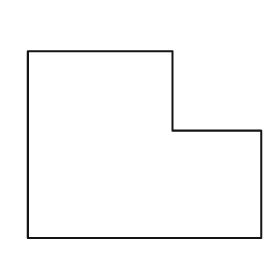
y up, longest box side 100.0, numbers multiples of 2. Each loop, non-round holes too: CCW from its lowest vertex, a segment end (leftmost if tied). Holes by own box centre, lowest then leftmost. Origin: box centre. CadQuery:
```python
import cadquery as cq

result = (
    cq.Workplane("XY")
    .moveTo(-50.0, -40.0)
    .lineTo(50.0, -40.0)
    .lineTo(50.0, 6.0)
    .lineTo(12.0, 6.0)
    .lineTo(12.0, 40.0)
    .lineTo(-50.0, 40.0)
    .close()
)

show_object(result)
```